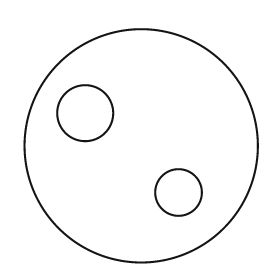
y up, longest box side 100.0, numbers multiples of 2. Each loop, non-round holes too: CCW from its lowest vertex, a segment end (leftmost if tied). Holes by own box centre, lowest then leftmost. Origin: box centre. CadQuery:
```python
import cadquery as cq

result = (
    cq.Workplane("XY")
    .moveTo(0.0, 0.0)
    .circle(50.0)
    .moveTo(16.0, -20.0)
    .circle(10.0)
    .moveTo(-24.0, 14.0)
    .circle(12.0)
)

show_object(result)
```